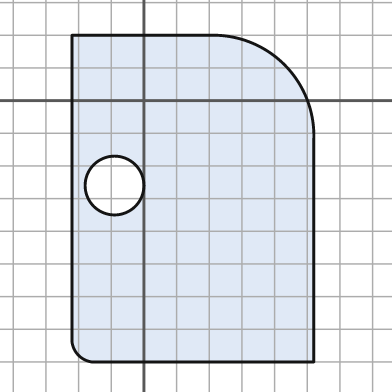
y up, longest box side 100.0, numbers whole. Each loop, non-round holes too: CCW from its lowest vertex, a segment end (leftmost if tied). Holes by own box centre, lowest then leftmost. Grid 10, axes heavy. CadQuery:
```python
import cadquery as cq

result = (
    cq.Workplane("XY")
    .moveTo(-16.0, -80.0)
    .lineTo(52.0, -80.0)
    .lineTo(52.0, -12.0)
    .threePointArc((43.0, 11.0), (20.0, 20.0))
    .lineTo(-22.0, 20.0)
    .lineTo(-22.0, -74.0)
    .threePointArc((-20.0, -78.0), (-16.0, -80.0))
    .close()
    .moveTo(-9.0, -26.0)
    .circle(9.0)
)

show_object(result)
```